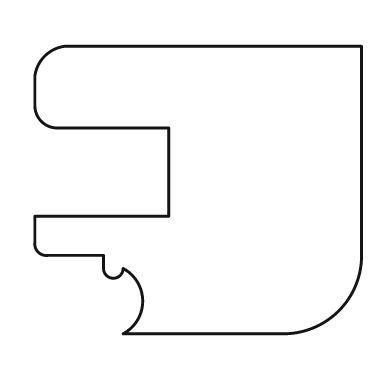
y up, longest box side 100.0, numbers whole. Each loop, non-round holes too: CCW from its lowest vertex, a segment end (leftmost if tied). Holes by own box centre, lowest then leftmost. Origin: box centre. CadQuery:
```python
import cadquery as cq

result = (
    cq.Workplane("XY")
    .moveTo(-23.0, -44.0)
    .lineTo(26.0, -44.0)
    .threePointArc((43.0, -37.0), (50.0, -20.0))
    .lineTo(50.0, 44.0)
    .lineTo(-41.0, 44.0)
    .threePointArc((-47.0, 41.0), (-50.0, 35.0))
    .lineTo(-50.0, 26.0)
    .threePointArc((-48.0, 21.0), (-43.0, 19.0))
    .lineTo(-9.0, 19.0)
    .lineTo(-9.0, -8.0)
    .lineTo(-50.0, -8.0)
    .lineTo(-50.0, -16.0)
    .threePointArc((-49.0, -19.0), (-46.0, -20.0))
    .lineTo(-29.0, -20.0)
    .lineTo(-29.0, -24.0)
    .threePointArc((-26.0, -27.0), (-23.0, -24.0))
    .threePointArc((-17.0, -34.0), (-23.0, -44.0))
    .close()
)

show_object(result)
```